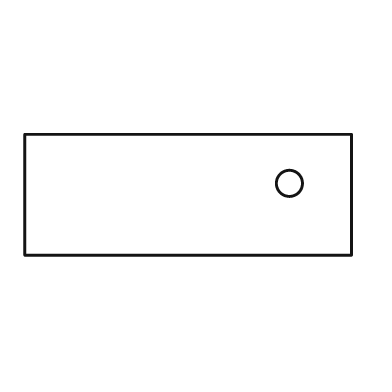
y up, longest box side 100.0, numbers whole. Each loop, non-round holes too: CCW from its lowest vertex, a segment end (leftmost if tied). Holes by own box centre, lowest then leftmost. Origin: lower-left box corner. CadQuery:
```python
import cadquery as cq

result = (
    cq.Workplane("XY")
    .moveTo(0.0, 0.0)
    .lineTo(100.0, 0.0)
    .lineTo(100.0, 37.0)
    .lineTo(0.0, 37.0)
    .close()
    .moveTo(81.0, 22.0)
    .circle(4.0)
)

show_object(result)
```